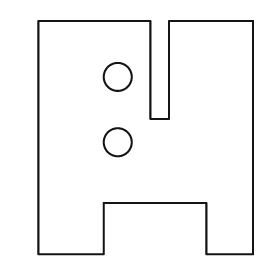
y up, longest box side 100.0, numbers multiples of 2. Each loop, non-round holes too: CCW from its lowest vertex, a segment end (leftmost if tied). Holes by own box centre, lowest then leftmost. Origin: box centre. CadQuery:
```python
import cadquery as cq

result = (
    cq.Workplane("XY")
    .moveTo(-46.0, -50.0)
    .lineTo(-18.0, -50.0)
    .lineTo(-18.0, -28.0)
    .lineTo(26.0, -28.0)
    .lineTo(26.0, -50.0)
    .lineTo(46.0, -50.0)
    .lineTo(46.0, 50.0)
    .lineTo(10.0, 50.0)
    .lineTo(10.0, 8.0)
    .lineTo(2.0, 8.0)
    .lineTo(2.0, 50.0)
    .lineTo(-46.0, 50.0)
    .close()
    .moveTo(-12.0, -2.0)
    .circle(6.0)
    .moveTo(-12.0, 26.0)
    .circle(6.0)
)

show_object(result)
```